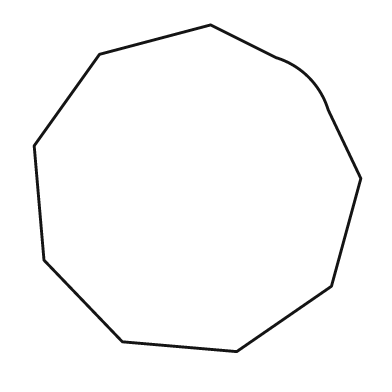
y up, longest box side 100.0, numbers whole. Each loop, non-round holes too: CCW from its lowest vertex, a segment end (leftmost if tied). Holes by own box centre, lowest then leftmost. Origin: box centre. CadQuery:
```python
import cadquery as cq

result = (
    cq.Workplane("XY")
    .moveTo(12.0, -50.0)
    .lineTo(41.0, -30.0)
    .lineTo(50.0, 3.0)
    .lineTo(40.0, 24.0)
    .threePointArc((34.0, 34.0), (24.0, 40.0))
    .lineTo(4.0, 50.0)
    .lineTo(-30.0, 41.0)
    .lineTo(-50.0, 13.0)
    .lineTo(-47.0, -22.0)
    .lineTo(-23.0, -47.0)
    .close()
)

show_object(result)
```